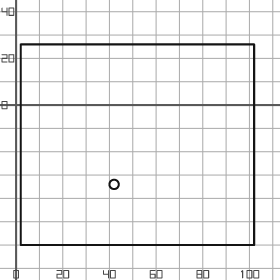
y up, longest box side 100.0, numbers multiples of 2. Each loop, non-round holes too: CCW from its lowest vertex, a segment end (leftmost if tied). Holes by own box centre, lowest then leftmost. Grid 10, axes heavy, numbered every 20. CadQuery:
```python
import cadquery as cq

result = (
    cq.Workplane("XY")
    .moveTo(2.0, -60.0)
    .lineTo(102.0, -60.0)
    .lineTo(102.0, 26.0)
    .lineTo(2.0, 26.0)
    .close()
    .moveTo(42.0, -34.0)
    .circle(2.0)
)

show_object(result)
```